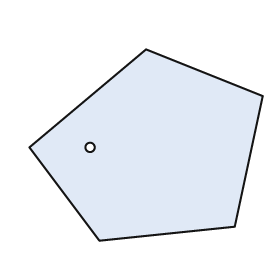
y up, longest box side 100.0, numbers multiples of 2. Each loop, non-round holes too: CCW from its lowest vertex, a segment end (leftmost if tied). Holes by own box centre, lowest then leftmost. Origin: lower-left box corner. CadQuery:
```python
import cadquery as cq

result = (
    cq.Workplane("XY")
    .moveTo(30.0, 0.0)
    .lineTo(88.0, 6.0)
    .lineTo(100.0, 62.0)
    .lineTo(50.0, 82.0)
    .lineTo(0.0, 40.0)
    .close()
    .moveTo(26.0, 40.0)
    .circle(2.0)
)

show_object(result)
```